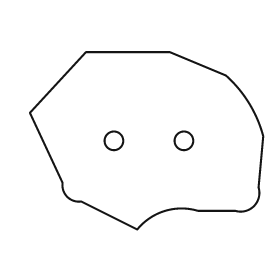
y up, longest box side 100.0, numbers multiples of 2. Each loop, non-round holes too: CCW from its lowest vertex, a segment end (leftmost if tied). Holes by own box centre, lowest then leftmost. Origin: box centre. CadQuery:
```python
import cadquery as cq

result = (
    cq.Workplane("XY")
    .moveTo(-4.0, -38.0)
    .threePointArc((8.0, -30.0), (22.0, -30.0))
    .lineTo(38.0, -30.0)
    .threePointArc((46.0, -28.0), (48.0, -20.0))
    .lineTo(50.0, 2.0)
    .threePointArc((44.0, 16.0), (34.0, 28.0))
    .lineTo(10.0, 38.0)
    .lineTo(-26.0, 38.0)
    .lineTo(-50.0, 12.0)
    .lineTo(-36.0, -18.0)
    .threePointArc((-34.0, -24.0), (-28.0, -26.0))
    .close()
    .moveTo(-14.0, 0.0)
    .circle(4.0)
    .moveTo(16.0, 0.0)
    .circle(4.0)
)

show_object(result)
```